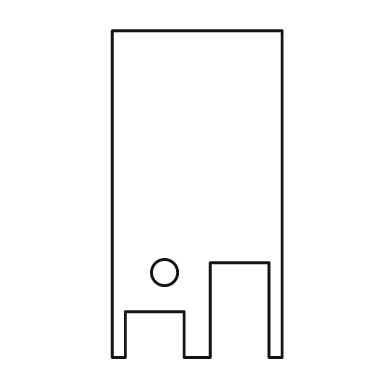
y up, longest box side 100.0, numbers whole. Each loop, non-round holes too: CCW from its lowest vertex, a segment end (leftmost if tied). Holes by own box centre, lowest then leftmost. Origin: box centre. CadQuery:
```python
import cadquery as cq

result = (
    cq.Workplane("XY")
    .moveTo(-26.0, -50.0)
    .lineTo(-22.0, -50.0)
    .lineTo(-22.0, -36.0)
    .lineTo(-4.0, -36.0)
    .lineTo(-4.0, -50.0)
    .lineTo(4.0, -50.0)
    .lineTo(4.0, -21.0)
    .lineTo(22.0, -21.0)
    .lineTo(22.0, -50.0)
    .lineTo(26.0, -50.0)
    .lineTo(26.0, 50.0)
    .lineTo(-26.0, 50.0)
    .close()
    .moveTo(-10.0, -24.0)
    .circle(4.0)
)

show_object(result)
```